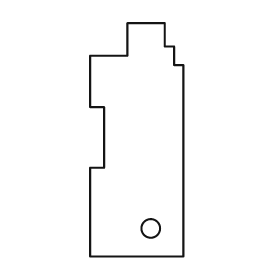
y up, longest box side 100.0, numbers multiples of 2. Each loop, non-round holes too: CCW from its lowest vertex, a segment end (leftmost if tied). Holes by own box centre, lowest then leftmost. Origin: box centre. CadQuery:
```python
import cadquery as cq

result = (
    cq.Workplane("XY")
    .moveTo(-20.0, -50.0)
    .lineTo(20.0, -50.0)
    .lineTo(20.0, 32.0)
    .lineTo(16.0, 32.0)
    .lineTo(16.0, 40.0)
    .lineTo(12.0, 40.0)
    .lineTo(12.0, 50.0)
    .lineTo(-4.0, 50.0)
    .lineTo(-4.0, 36.0)
    .lineTo(-20.0, 36.0)
    .lineTo(-20.0, 14.0)
    .lineTo(-14.0, 14.0)
    .lineTo(-14.0, -12.0)
    .lineTo(-20.0, -12.0)
    .close()
    .moveTo(6.0, -38.0)
    .circle(4.0)
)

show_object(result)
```